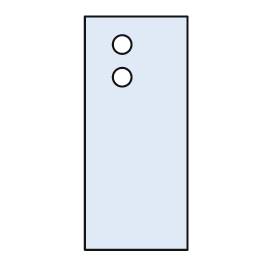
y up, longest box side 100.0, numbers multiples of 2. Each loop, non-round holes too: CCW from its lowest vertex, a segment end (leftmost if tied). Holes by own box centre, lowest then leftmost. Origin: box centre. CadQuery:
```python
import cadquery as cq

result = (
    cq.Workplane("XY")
    .moveTo(-22.0, -50.0)
    .lineTo(22.0, -50.0)
    .lineTo(22.0, 50.0)
    .lineTo(-22.0, 50.0)
    .close()
    .moveTo(-6.0, 24.0)
    .circle(4.0)
    .moveTo(-6.0, 38.0)
    .circle(4.0)
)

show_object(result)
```